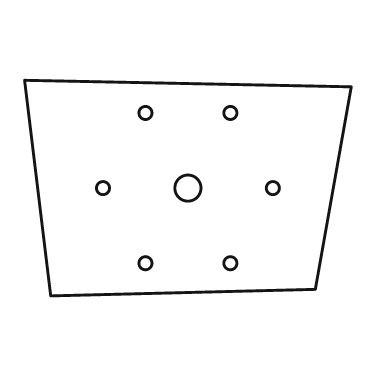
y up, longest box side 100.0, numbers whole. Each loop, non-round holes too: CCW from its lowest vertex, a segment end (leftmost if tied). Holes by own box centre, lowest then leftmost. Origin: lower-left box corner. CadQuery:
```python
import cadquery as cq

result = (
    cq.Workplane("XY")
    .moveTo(8.0, 0.0)
    .lineTo(89.0, 2.0)
    .lineTo(100.0, 64.0)
    .lineTo(0.0, 66.0)
    .close()
    .moveTo(37.0, 10.0)
    .circle(2.0)
    .moveTo(63.0, 10.0)
    .circle(2.0)
    .moveTo(24.0, 33.0)
    .circle(2.0)
    .moveTo(50.0, 33.0)
    .circle(4.0)
    .moveTo(76.0, 33.0)
    .circle(2.0)
    .moveTo(37.0, 56.0)
    .circle(2.0)
    .moveTo(63.0, 56.0)
    .circle(2.0)
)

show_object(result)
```